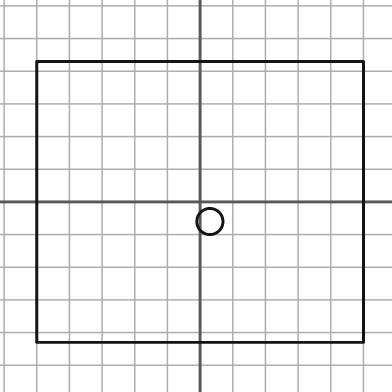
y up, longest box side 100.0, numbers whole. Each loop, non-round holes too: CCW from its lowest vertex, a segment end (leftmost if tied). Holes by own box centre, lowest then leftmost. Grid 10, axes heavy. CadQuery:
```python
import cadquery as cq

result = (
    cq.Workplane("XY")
    .moveTo(-50.0, -43.0)
    .lineTo(50.0, -43.0)
    .lineTo(50.0, 43.0)
    .lineTo(-50.0, 43.0)
    .close()
    .moveTo(3.0, -6.0)
    .circle(4.0)
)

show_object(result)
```